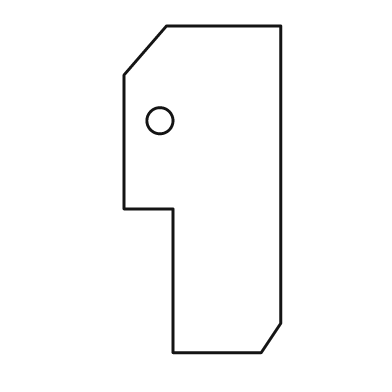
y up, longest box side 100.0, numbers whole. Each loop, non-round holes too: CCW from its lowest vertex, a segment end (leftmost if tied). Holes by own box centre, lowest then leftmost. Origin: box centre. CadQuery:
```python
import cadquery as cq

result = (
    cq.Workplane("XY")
    .moveTo(-9.0, -50.0)
    .lineTo(18.0, -50.0)
    .lineTo(24.0, -41.0)
    .lineTo(24.0, 50.0)
    .lineTo(-11.0, 50.0)
    .lineTo(-24.0, 35.0)
    .lineTo(-24.0, -6.0)
    .lineTo(-9.0, -6.0)
    .close()
    .moveTo(-13.0, 21.0)
    .circle(4.0)
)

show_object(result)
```